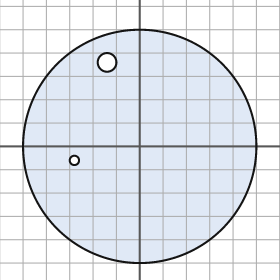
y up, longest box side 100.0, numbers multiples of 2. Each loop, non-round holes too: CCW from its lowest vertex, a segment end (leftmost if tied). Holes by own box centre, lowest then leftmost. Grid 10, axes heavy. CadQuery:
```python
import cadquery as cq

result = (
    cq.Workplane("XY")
    .moveTo(0.0, 0.0)
    .circle(50.0)
    .moveTo(-28.0, -6.0)
    .circle(2.0)
    .moveTo(-14.0, 36.0)
    .circle(4.0)
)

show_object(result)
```